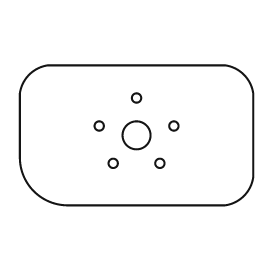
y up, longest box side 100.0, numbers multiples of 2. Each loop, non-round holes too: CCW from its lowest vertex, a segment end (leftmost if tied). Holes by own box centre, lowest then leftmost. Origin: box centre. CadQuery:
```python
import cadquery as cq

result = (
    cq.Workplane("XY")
    .moveTo(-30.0, -30.0)
    .lineTo(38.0, -30.0)
    .threePointArc((46.0, -26.0), (50.0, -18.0))
    .lineTo(50.0, 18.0)
    .threePointArc((46.0, 26.0), (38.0, 30.0))
    .lineTo(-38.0, 30.0)
    .threePointArc((-46.0, 26.0), (-50.0, 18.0))
    .lineTo(-50.0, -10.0)
    .threePointArc((-44.0, -24.0), (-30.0, -30.0))
    .close()
    .moveTo(-10.0, -12.0)
    .circle(2.0)
    .moveTo(10.0, -12.0)
    .circle(2.0)
    .moveTo(0.0, 0.0)
    .circle(6.0)
    .moveTo(-16.0, 4.0)
    .circle(2.0)
    .moveTo(16.0, 4.0)
    .circle(2.0)
    .moveTo(0.0, 16.0)
    .circle(2.0)
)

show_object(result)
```